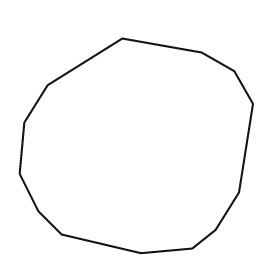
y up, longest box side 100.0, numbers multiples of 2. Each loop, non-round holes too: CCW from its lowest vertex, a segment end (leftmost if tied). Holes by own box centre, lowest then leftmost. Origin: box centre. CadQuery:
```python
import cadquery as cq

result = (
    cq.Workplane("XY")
    .moveTo(2.0, -46.0)
    .lineTo(24.0, -44.0)
    .lineTo(34.0, -36.0)
    .lineTo(44.0, -20.0)
    .lineTo(50.0, 18.0)
    .lineTo(42.0, 32.0)
    .lineTo(28.0, 40.0)
    .lineTo(-6.0, 46.0)
    .lineTo(-38.0, 26.0)
    .lineTo(-48.0, 10.0)
    .lineTo(-50.0, -12.0)
    .lineTo(-42.0, -28.0)
    .lineTo(-32.0, -38.0)
    .close()
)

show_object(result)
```